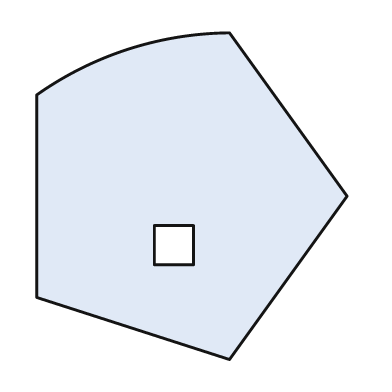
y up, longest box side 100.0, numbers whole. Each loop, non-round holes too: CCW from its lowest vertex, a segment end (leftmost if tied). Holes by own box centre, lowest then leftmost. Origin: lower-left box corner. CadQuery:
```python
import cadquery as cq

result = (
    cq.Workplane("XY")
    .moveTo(59.0, 0.0)
    .lineTo(95.0, 50.0)
    .lineTo(59.0, 100.0)
    .threePointArc((28.0, 95.0), (0.0, 81.0))
    .lineTo(0.0, 19.0)
    .close()
    .moveTo(36.0, 29.0)
    .lineTo(48.0, 29.0)
    .lineTo(48.0, 41.0)
    .lineTo(36.0, 41.0)
    .close()
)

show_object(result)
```